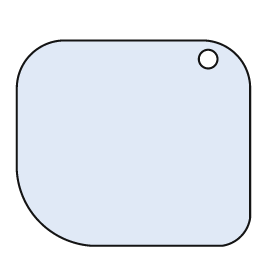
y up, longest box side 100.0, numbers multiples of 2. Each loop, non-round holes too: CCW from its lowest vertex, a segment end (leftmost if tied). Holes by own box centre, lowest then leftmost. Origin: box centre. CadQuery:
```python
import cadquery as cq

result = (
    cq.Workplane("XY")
    .moveTo(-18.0, -44.0)
    .lineTo(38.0, -44.0)
    .threePointArc((46.0, -40.0), (50.0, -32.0))
    .lineTo(50.0, 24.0)
    .threePointArc((44.0, 38.0), (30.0, 44.0))
    .lineTo(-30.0, 44.0)
    .threePointArc((-44.0, 38.0), (-50.0, 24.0))
    .lineTo(-50.0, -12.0)
    .threePointArc((-40.0, -34.0), (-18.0, -44.0))
    .close()
    .moveTo(32.0, 36.0)
    .circle(4.0)
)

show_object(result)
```